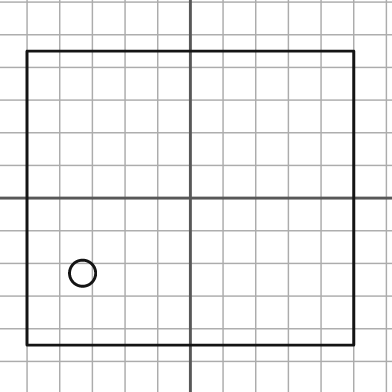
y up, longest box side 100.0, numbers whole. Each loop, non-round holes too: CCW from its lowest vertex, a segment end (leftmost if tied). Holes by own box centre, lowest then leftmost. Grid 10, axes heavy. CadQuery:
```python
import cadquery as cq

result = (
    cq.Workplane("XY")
    .moveTo(-50.0, -45.0)
    .lineTo(50.0, -45.0)
    .lineTo(50.0, 45.0)
    .lineTo(-50.0, 45.0)
    .close()
    .moveTo(-33.0, -23.0)
    .circle(4.0)
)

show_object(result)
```